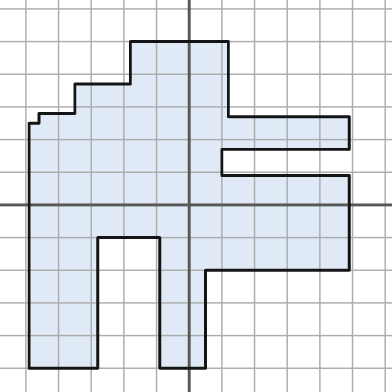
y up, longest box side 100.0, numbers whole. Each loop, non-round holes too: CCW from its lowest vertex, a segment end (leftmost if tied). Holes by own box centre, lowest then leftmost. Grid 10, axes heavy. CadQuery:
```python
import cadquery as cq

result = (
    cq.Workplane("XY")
    .moveTo(-49.0, -50.0)
    .lineTo(-28.0, -50.0)
    .lineTo(-28.0, -10.0)
    .lineTo(-9.0, -10.0)
    .lineTo(-9.0, -50.0)
    .lineTo(5.0, -50.0)
    .lineTo(5.0, -20.0)
    .lineTo(49.0, -20.0)
    .lineTo(49.0, 9.0)
    .lineTo(10.0, 9.0)
    .lineTo(10.0, 17.0)
    .lineTo(49.0, 17.0)
    .lineTo(49.0, 27.0)
    .lineTo(12.0, 27.0)
    .lineTo(12.0, 50.0)
    .lineTo(-18.0, 50.0)
    .lineTo(-18.0, 37.0)
    .lineTo(-35.0, 37.0)
    .lineTo(-35.0, 28.0)
    .lineTo(-46.0, 28.0)
    .lineTo(-46.0, 25.0)
    .lineTo(-49.0, 25.0)
    .close()
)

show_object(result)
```